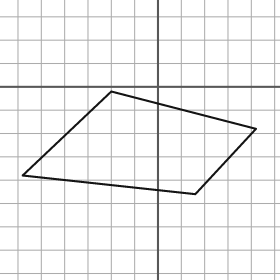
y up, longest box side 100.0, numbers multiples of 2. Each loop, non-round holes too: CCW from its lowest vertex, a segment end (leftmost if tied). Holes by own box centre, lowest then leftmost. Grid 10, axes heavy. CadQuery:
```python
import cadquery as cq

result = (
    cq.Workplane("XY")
    .moveTo(16.0, -46.0)
    .lineTo(42.0, -18.0)
    .lineTo(-20.0, -2.0)
    .lineTo(-58.0, -38.0)
    .close()
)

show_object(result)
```